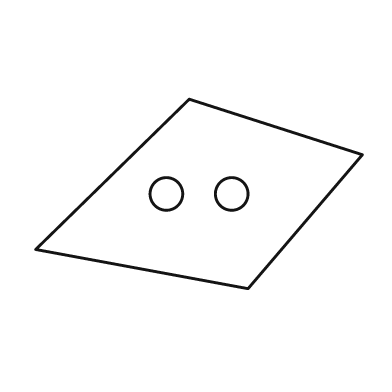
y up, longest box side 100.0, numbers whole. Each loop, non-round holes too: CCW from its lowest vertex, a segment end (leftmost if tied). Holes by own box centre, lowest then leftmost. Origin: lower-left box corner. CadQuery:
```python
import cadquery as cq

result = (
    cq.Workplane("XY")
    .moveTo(65.0, 0.0)
    .lineTo(100.0, 41.0)
    .lineTo(47.0, 58.0)
    .lineTo(0.0, 12.0)
    .close()
    .moveTo(40.0, 29.0)
    .circle(5.0)
    .moveTo(60.0, 29.0)
    .circle(5.0)
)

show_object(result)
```